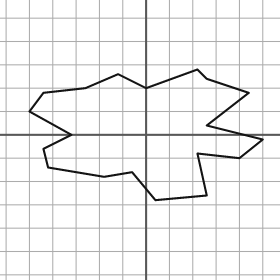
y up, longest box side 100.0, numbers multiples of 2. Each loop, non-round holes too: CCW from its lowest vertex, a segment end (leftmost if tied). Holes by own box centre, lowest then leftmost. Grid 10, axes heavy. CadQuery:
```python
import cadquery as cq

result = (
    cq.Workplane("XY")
    .moveTo(4.0, -28.0)
    .lineTo(26.0, -26.0)
    .lineTo(22.0, -8.0)
    .lineTo(40.0, -10.0)
    .lineTo(50.0, -2.0)
    .lineTo(26.0, 4.0)
    .lineTo(44.0, 18.0)
    .lineTo(26.0, 24.0)
    .lineTo(22.0, 28.0)
    .lineTo(0.0, 20.0)
    .lineTo(-12.0, 26.0)
    .lineTo(-26.0, 20.0)
    .lineTo(-44.0, 18.0)
    .lineTo(-50.0, 10.0)
    .lineTo(-32.0, 0.0)
    .lineTo(-44.0, -6.0)
    .lineTo(-42.0, -14.0)
    .lineTo(-18.0, -18.0)
    .lineTo(-6.0, -16.0)
    .close()
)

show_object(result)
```